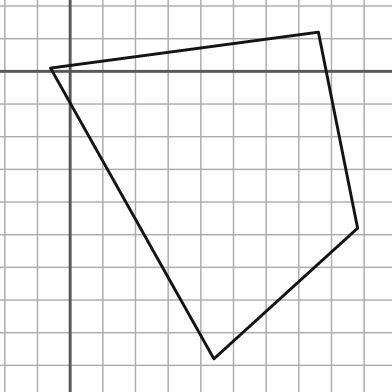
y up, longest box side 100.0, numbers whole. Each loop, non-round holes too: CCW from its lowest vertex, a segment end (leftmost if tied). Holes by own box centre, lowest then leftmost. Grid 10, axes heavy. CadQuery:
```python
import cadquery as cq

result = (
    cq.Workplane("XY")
    .moveTo(44.0, -88.0)
    .lineTo(88.0, -48.0)
    .lineTo(76.0, 12.0)
    .lineTo(-6.0, 1.0)
    .close()
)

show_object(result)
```